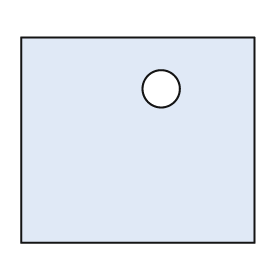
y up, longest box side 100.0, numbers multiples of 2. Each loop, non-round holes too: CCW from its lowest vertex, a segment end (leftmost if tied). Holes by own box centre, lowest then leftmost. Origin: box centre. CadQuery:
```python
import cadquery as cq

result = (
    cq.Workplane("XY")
    .moveTo(-50.0, -44.0)
    .lineTo(50.0, -44.0)
    .lineTo(50.0, 44.0)
    .lineTo(-50.0, 44.0)
    .close()
    .moveTo(10.0, 22.0)
    .circle(8.0)
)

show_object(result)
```